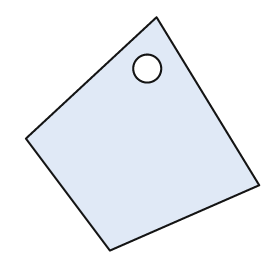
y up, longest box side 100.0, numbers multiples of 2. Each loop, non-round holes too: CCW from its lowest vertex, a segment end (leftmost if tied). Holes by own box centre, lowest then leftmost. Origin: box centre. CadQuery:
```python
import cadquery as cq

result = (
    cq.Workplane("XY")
    .moveTo(-14.0, -50.0)
    .lineTo(50.0, -22.0)
    .lineTo(6.0, 50.0)
    .lineTo(-50.0, -2.0)
    .close()
    .moveTo(2.0, 28.0)
    .circle(6.0)
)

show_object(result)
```